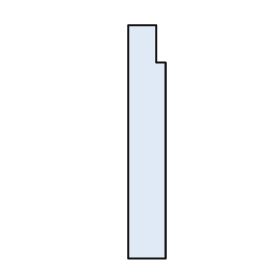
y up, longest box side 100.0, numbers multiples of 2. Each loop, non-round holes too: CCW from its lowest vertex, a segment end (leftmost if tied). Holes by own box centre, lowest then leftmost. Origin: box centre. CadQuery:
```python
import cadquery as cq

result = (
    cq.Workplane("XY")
    .moveTo(-8.0, -50.0)
    .lineTo(8.0, -50.0)
    .lineTo(8.0, 34.0)
    .lineTo(4.0, 34.0)
    .lineTo(4.0, 50.0)
    .lineTo(-8.0, 50.0)
    .close()
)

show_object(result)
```